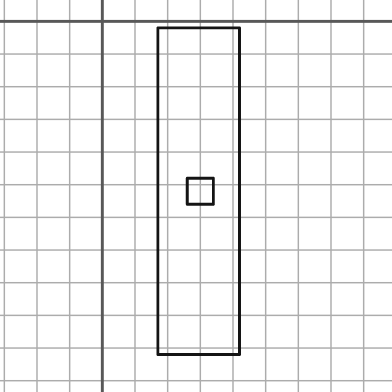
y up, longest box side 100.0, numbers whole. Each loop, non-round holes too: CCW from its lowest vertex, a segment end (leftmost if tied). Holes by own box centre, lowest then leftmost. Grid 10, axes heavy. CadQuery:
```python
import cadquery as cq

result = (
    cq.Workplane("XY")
    .moveTo(17.0, -102.0)
    .lineTo(42.0, -102.0)
    .lineTo(42.0, -2.0)
    .lineTo(17.0, -2.0)
    .close()
    .moveTo(26.0, -56.0)
    .lineTo(34.0, -56.0)
    .lineTo(34.0, -48.0)
    .lineTo(26.0, -48.0)
    .close()
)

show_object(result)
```